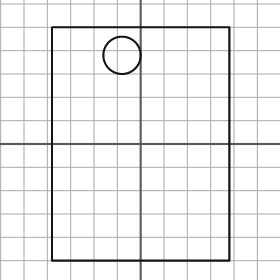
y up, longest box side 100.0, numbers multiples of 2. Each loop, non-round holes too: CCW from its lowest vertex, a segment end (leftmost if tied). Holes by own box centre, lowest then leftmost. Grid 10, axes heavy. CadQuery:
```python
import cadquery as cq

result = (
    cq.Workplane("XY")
    .moveTo(-38.0, -50.0)
    .lineTo(38.0, -50.0)
    .lineTo(38.0, 50.0)
    .lineTo(-38.0, 50.0)
    .close()
    .moveTo(-8.0, 38.0)
    .circle(8.0)
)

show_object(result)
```